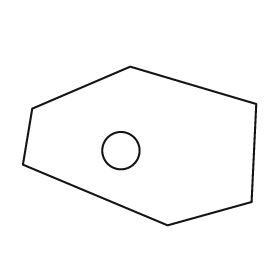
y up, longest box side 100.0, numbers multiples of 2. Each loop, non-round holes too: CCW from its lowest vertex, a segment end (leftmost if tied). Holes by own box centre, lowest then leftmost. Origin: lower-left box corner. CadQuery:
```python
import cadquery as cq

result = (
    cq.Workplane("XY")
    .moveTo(62.0, 0.0)
    .lineTo(98.0, 10.0)
    .lineTo(100.0, 52.0)
    .lineTo(46.0, 68.0)
    .lineTo(4.0, 50.0)
    .lineTo(0.0, 26.0)
    .close()
    .moveTo(42.0, 32.0)
    .circle(8.0)
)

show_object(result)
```